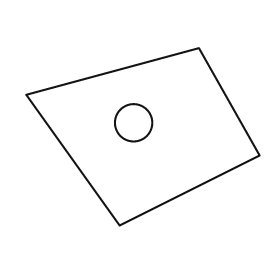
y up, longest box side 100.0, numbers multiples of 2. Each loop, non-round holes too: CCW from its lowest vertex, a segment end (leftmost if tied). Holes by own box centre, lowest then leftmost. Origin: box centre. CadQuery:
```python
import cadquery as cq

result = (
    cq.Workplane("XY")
    .moveTo(-10.0, -38.0)
    .lineTo(50.0, -8.0)
    .lineTo(24.0, 38.0)
    .lineTo(-50.0, 18.0)
    .close()
    .moveTo(-4.0, 6.0)
    .circle(8.0)
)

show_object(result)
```